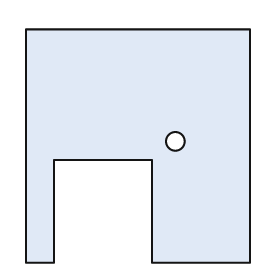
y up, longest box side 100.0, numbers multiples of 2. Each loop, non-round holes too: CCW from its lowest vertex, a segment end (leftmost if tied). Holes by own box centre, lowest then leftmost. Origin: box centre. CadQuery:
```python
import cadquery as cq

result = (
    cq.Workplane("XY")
    .moveTo(-48.0, -50.0)
    .lineTo(-36.0, -50.0)
    .lineTo(-36.0, -6.0)
    .lineTo(6.0, -6.0)
    .lineTo(6.0, -50.0)
    .lineTo(48.0, -50.0)
    .lineTo(48.0, 50.0)
    .lineTo(-48.0, 50.0)
    .close()
    .moveTo(16.0, 2.0)
    .circle(4.0)
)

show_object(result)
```